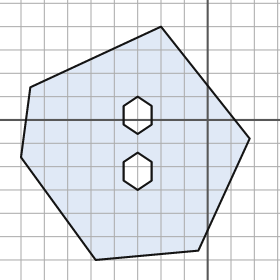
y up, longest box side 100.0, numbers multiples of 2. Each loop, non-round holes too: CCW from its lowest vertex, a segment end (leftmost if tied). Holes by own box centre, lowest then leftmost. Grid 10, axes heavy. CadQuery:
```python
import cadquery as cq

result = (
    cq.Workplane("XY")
    .moveTo(-48.0, -60.0)
    .lineTo(-4.0, -56.0)
    .lineTo(18.0, -8.0)
    .lineTo(-20.0, 40.0)
    .lineTo(-76.0, 14.0)
    .lineTo(-80.0, -16.0)
    .close()
    .moveTo(-30.0, -30.0)
    .lineTo(-24.0, -26.0)
    .lineTo(-24.0, -18.0)
    .lineTo(-30.0, -14.0)
    .lineTo(-36.0, -18.0)
    .lineTo(-36.0, -26.0)
    .close()
    .moveTo(-30.0, -6.0)
    .lineTo(-24.0, -2.0)
    .lineTo(-24.0, 6.0)
    .lineTo(-30.0, 10.0)
    .lineTo(-36.0, 6.0)
    .lineTo(-36.0, -2.0)
    .close()
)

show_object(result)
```